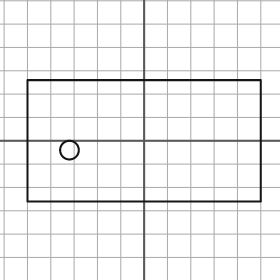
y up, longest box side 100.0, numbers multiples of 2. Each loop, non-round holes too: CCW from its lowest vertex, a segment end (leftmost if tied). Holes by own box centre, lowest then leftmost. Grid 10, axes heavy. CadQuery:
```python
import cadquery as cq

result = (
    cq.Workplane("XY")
    .moveTo(-50.0, -26.0)
    .lineTo(50.0, -26.0)
    .lineTo(50.0, 26.0)
    .lineTo(-50.0, 26.0)
    .close()
    .moveTo(-32.0, -4.0)
    .circle(4.0)
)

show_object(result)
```